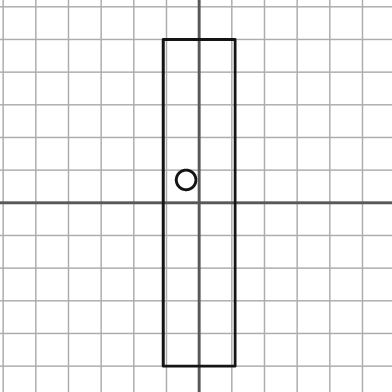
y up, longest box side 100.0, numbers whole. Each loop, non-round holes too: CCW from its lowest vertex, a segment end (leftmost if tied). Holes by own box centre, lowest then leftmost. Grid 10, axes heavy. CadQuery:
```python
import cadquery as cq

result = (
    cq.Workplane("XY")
    .moveTo(-11.0, -50.0)
    .lineTo(11.0, -50.0)
    .lineTo(11.0, 50.0)
    .lineTo(-11.0, 50.0)
    .close()
    .moveTo(-4.0, 7.0)
    .circle(3.0)
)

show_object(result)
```